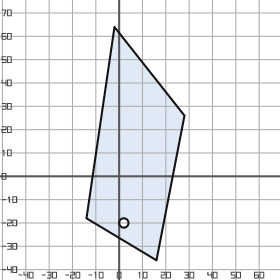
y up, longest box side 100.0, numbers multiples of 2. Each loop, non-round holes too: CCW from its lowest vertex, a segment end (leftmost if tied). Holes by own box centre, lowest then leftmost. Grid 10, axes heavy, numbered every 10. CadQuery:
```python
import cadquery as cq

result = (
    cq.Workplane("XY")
    .moveTo(16.0, -36.0)
    .lineTo(28.0, 26.0)
    .lineTo(-2.0, 64.0)
    .lineTo(-14.0, -18.0)
    .close()
    .moveTo(2.0, -20.0)
    .circle(2.0)
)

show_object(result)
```